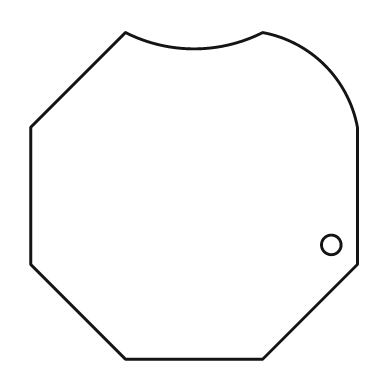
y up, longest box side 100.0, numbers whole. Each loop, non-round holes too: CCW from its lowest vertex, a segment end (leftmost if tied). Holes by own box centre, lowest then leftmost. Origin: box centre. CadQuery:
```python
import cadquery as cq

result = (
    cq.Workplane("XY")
    .moveTo(-21.0, -50.0)
    .lineTo(21.0, -50.0)
    .lineTo(50.0, -21.0)
    .lineTo(50.0, 21.0)
    .threePointArc((40.0, 40.0), (21.0, 50.0))
    .threePointArc((0.0, 45.0), (-21.0, 50.0))
    .lineTo(-50.0, 21.0)
    .lineTo(-50.0, -21.0)
    .close()
    .moveTo(42.0, -15.0)
    .circle(3.0)
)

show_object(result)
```